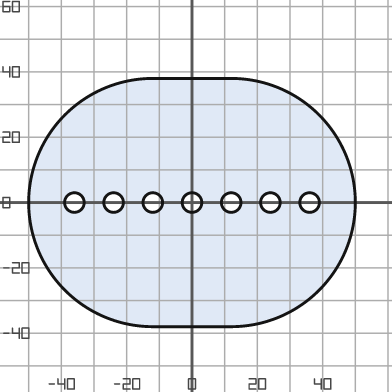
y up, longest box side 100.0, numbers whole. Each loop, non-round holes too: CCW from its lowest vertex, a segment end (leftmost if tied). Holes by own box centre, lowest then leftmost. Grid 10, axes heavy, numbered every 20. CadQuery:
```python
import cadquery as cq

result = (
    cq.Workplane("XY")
    .moveTo(-12.0, -38.0)
    .lineTo(12.0, -38.0)
    .threePointArc((50.0, 0.0), (12.0, 38.0))
    .lineTo(-12.0, 38.0)
    .threePointArc((-50.0, 0.0), (-12.0, -38.0))
    .close()
    .moveTo(-36.0, 0.0)
    .circle(3.0)
    .moveTo(-24.0, 0.0)
    .circle(3.0)
    .moveTo(-12.0, 0.0)
    .circle(3.0)
    .moveTo(0.0, 0.0)
    .circle(3.0)
    .moveTo(12.0, 0.0)
    .circle(3.0)
    .moveTo(24.0, 0.0)
    .circle(3.0)
    .moveTo(36.0, 0.0)
    .circle(3.0)
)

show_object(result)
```